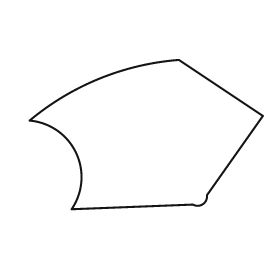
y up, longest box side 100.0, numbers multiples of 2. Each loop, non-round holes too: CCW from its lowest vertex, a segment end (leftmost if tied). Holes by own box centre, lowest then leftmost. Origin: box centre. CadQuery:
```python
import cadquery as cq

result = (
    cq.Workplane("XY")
    .moveTo(-32.0, -32.0)
    .lineTo(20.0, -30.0)
    .threePointArc((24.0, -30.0), (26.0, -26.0))
    .lineTo(50.0, 8.0)
    .lineTo(14.0, 32.0)
    .threePointArc((-20.0, 24.0), (-50.0, 6.0))
    .threePointArc((-30.0, -8.0), (-32.0, -32.0))
    .close()
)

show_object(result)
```